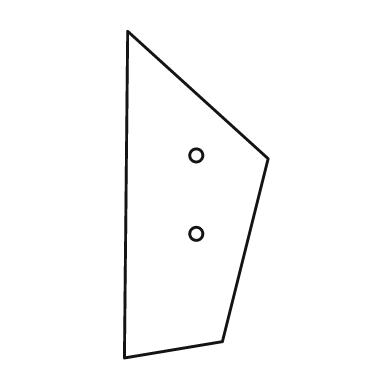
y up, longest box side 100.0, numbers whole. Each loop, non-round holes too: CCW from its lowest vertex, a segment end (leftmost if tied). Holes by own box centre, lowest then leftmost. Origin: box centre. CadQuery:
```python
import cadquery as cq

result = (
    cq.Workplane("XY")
    .moveTo(-22.0, -50.0)
    .lineTo(8.0, -45.0)
    .lineTo(22.0, 11.0)
    .lineTo(-21.0, 50.0)
    .close()
    .moveTo(0.0, -12.0)
    .circle(2.0)
    .moveTo(0.0, 12.0)
    .circle(2.0)
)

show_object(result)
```